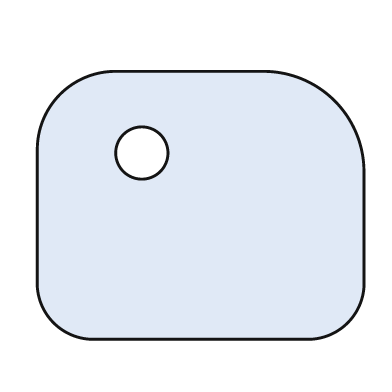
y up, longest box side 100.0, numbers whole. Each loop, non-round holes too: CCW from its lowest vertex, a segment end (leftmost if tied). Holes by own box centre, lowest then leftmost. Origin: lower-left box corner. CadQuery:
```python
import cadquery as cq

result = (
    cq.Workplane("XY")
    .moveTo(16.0, 0.0)
    .lineTo(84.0, 0.0)
    .threePointArc((95.0, 5.0), (100.0, 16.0))
    .lineTo(100.0, 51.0)
    .threePointArc((91.0, 73.0), (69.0, 82.0))
    .lineTo(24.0, 82.0)
    .threePointArc((7.0, 75.0), (0.0, 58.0))
    .lineTo(0.0, 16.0)
    .threePointArc((5.0, 5.0), (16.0, 0.0))
    .close()
    .moveTo(32.0, 57.0)
    .circle(8.0)
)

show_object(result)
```